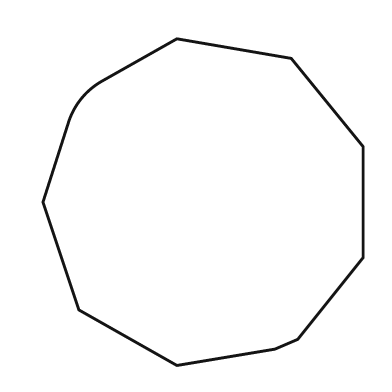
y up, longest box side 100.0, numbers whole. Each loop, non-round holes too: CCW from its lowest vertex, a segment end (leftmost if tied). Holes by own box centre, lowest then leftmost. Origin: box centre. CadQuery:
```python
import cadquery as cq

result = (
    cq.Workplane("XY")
    .moveTo(-8.0, -50.0)
    .lineTo(22.0, -45.0)
    .lineTo(29.0, -42.0)
    .lineTo(49.0, -17.0)
    .lineTo(49.0, 17.0)
    .lineTo(27.0, 44.0)
    .lineTo(-8.0, 50.0)
    .lineTo(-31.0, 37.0)
    .threePointArc((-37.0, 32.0), (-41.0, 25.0))
    .lineTo(-49.0, 0.0)
    .lineTo(-38.0, -33.0)
    .close()
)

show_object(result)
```